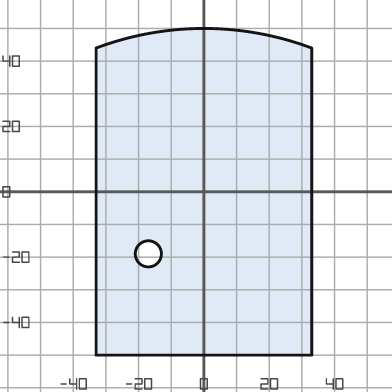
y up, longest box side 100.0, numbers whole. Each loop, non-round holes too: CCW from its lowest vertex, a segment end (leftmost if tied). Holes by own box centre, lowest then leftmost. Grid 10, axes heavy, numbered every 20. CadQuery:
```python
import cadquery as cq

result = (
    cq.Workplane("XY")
    .moveTo(-33.0, -50.0)
    .lineTo(33.0, -50.0)
    .lineTo(33.0, 44.0)
    .threePointArc((0.0, 50.0), (-33.0, 44.0))
    .close()
    .moveTo(-17.0, -19.0)
    .circle(4.0)
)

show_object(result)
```